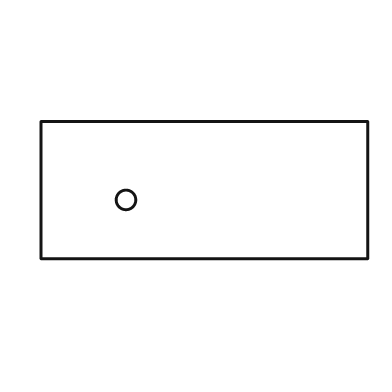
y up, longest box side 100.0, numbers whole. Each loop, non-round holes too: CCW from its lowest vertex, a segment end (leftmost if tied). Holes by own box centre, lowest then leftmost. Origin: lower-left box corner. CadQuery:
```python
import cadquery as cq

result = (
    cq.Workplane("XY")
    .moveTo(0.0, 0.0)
    .lineTo(100.0, 0.0)
    .lineTo(100.0, 42.0)
    .lineTo(0.0, 42.0)
    .close()
    .moveTo(26.0, 18.0)
    .circle(3.0)
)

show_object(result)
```